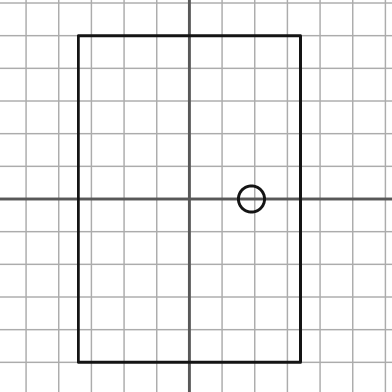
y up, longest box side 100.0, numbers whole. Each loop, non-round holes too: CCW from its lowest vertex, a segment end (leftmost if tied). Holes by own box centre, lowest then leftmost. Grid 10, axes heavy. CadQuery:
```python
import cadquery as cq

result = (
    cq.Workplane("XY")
    .moveTo(-34.0, -50.0)
    .lineTo(34.0, -50.0)
    .lineTo(34.0, 50.0)
    .lineTo(-34.0, 50.0)
    .close()
    .moveTo(19.0, 0.0)
    .circle(4.0)
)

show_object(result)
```